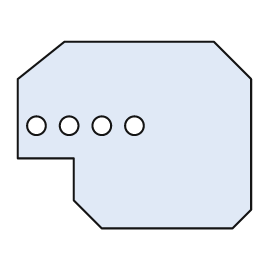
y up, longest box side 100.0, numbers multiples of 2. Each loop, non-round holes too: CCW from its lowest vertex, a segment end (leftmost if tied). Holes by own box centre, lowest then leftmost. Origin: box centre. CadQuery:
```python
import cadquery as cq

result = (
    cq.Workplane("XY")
    .moveTo(-14.0, -40.0)
    .lineTo(42.0, -40.0)
    .lineTo(50.0, -32.0)
    .lineTo(50.0, 24.0)
    .lineTo(34.0, 40.0)
    .lineTo(-30.0, 40.0)
    .lineTo(-50.0, 24.0)
    .lineTo(-50.0, -10.0)
    .lineTo(-26.0, -10.0)
    .lineTo(-26.0, -28.0)
    .close()
    .moveTo(-42.0, 4.0)
    .circle(4.0)
    .moveTo(-28.0, 4.0)
    .circle(4.0)
    .moveTo(-14.0, 4.0)
    .circle(4.0)
    .moveTo(0.0, 4.0)
    .circle(4.0)
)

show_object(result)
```